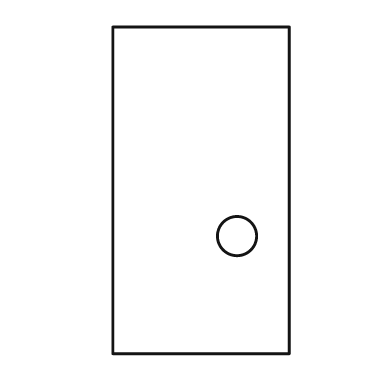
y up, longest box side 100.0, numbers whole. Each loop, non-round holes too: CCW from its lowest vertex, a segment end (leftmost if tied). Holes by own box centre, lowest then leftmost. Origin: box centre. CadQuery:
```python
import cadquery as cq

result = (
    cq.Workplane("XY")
    .moveTo(-27.0, -50.0)
    .lineTo(27.0, -50.0)
    .lineTo(27.0, 50.0)
    .lineTo(-27.0, 50.0)
    .close()
    .moveTo(11.0, -14.0)
    .circle(6.0)
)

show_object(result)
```